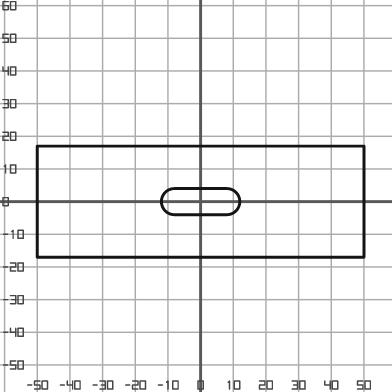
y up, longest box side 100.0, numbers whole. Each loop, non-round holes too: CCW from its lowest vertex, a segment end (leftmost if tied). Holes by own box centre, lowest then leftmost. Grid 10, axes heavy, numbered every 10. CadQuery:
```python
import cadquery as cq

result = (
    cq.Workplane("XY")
    .moveTo(-50.0, -17.0)
    .lineTo(50.0, -17.0)
    .lineTo(50.0, 17.0)
    .lineTo(-50.0, 17.0)
    .close()
    .moveTo(-8.0, -4.0)
    .lineTo(8.0, -4.0)
    .threePointArc((12.0, 0.0), (8.0, 4.0))
    .lineTo(-8.0, 4.0)
    .threePointArc((-12.0, 0.0), (-8.0, -4.0))
    .close()
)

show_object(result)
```